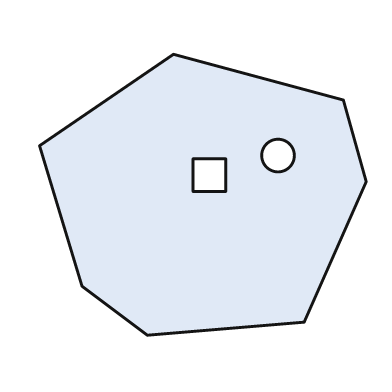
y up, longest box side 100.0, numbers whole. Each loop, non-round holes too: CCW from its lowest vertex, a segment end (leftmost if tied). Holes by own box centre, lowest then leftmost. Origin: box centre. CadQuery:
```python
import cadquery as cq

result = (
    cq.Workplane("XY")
    .moveTo(-17.0, -43.0)
    .lineTo(31.0, -39.0)
    .lineTo(50.0, 4.0)
    .lineTo(43.0, 29.0)
    .lineTo(-9.0, 43.0)
    .lineTo(-50.0, 15.0)
    .lineTo(-37.0, -28.0)
    .close()
    .moveTo(-3.0, 1.0)
    .lineTo(7.0, 1.0)
    .lineTo(7.0, 11.0)
    .lineTo(-3.0, 11.0)
    .close()
    .moveTo(23.0, 12.0)
    .circle(5.0)
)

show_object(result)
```